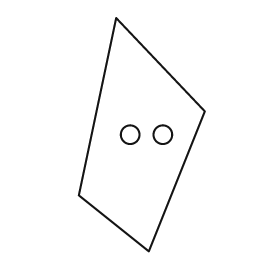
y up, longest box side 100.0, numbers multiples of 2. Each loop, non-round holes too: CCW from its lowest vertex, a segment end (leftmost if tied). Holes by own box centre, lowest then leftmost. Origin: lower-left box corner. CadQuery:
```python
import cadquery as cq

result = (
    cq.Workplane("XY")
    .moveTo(30.0, 0.0)
    .lineTo(54.0, 60.0)
    .lineTo(16.0, 100.0)
    .lineTo(0.0, 24.0)
    .close()
    .moveTo(22.0, 50.0)
    .circle(4.0)
    .moveTo(36.0, 50.0)
    .circle(4.0)
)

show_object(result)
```